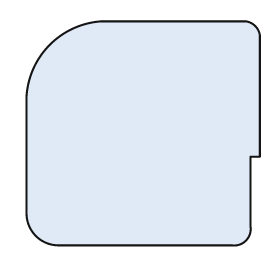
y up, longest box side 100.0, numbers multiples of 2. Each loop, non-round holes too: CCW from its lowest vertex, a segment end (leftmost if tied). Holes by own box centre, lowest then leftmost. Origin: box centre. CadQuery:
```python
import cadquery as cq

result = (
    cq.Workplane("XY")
    .moveTo(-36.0, -48.0)
    .lineTo(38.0, -48.0)
    .threePointArc((44.0, -46.0), (46.0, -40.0))
    .lineTo(46.0, -10.0)
    .lineTo(50.0, -10.0)
    .lineTo(50.0, 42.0)
    .threePointArc((48.0, 46.0), (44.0, 48.0))
    .lineTo(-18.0, 48.0)
    .threePointArc((-40.0, 38.0), (-50.0, 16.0))
    .lineTo(-50.0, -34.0)
    .threePointArc((-46.0, -44.0), (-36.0, -48.0))
    .close()
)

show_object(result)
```